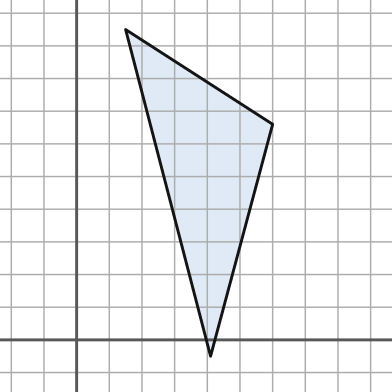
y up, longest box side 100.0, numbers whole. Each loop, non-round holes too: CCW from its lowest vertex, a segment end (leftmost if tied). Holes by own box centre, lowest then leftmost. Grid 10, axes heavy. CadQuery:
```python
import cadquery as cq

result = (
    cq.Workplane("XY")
    .moveTo(41.0, -5.0)
    .lineTo(60.0, 66.0)
    .lineTo(15.0, 95.0)
    .close()
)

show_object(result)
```